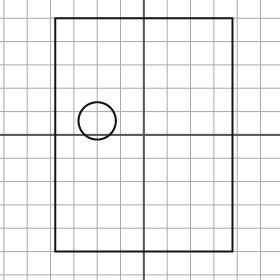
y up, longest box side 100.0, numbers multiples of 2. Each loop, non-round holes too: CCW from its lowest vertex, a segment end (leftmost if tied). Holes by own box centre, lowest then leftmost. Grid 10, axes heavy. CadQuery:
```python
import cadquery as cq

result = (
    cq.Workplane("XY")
    .moveTo(-38.0, -50.0)
    .lineTo(38.0, -50.0)
    .lineTo(38.0, 50.0)
    .lineTo(-38.0, 50.0)
    .close()
    .moveTo(-20.0, 6.0)
    .circle(8.0)
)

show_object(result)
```